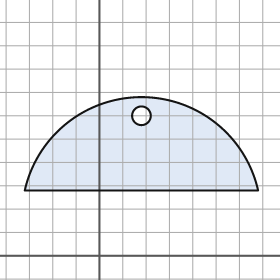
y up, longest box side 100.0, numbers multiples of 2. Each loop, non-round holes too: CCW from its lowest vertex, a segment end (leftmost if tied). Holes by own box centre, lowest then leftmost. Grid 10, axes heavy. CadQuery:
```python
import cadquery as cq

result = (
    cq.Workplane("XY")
    .moveTo(-32.0, 28.0)
    .lineTo(68.0, 28.0)
    .threePointArc((18.0, 68.0), (-32.0, 28.0))
    .close()
    .moveTo(18.0, 60.0)
    .circle(4.0)
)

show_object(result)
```